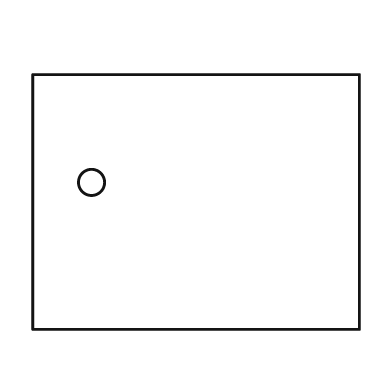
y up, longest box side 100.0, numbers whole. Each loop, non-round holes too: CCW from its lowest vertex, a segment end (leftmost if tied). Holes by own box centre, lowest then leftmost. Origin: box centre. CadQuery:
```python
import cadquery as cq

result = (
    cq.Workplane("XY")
    .moveTo(-50.0, -39.0)
    .lineTo(50.0, -39.0)
    .lineTo(50.0, 39.0)
    .lineTo(-50.0, 39.0)
    .close()
    .moveTo(-32.0, 6.0)
    .circle(4.0)
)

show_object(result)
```